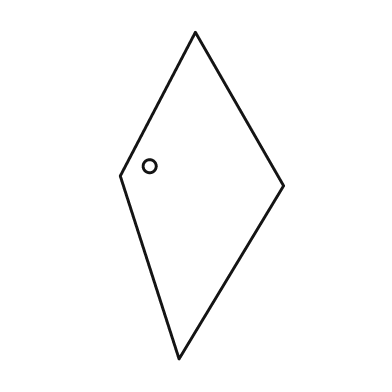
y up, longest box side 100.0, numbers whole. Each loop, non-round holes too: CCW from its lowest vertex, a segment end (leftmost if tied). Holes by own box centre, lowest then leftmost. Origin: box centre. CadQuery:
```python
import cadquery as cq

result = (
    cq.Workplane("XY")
    .moveTo(-7.0, -50.0)
    .lineTo(25.0, 3.0)
    .lineTo(-2.0, 50.0)
    .lineTo(-25.0, 6.0)
    .close()
    .moveTo(-16.0, 9.0)
    .circle(2.0)
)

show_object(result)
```